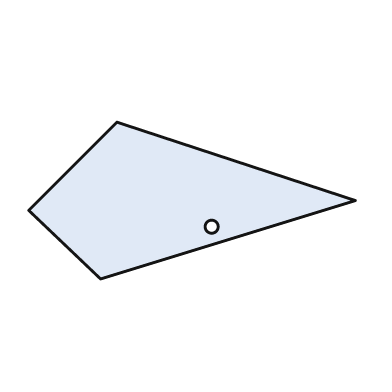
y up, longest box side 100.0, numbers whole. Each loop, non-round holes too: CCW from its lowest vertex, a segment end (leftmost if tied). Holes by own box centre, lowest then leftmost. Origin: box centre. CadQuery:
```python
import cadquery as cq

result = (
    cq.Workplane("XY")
    .moveTo(-28.0, -24.0)
    .lineTo(50.0, 0.0)
    .lineTo(-23.0, 24.0)
    .lineTo(-50.0, -3.0)
    .close()
    .moveTo(6.0, -8.0)
    .circle(2.0)
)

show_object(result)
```